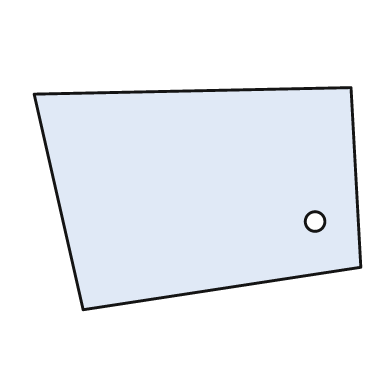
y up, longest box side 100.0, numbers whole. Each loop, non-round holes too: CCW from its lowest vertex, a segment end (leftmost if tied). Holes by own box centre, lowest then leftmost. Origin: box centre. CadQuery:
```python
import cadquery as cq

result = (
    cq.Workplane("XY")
    .moveTo(-35.0, -34.0)
    .lineTo(50.0, -21.0)
    .lineTo(47.0, 34.0)
    .lineTo(-50.0, 32.0)
    .close()
    .moveTo(36.0, -7.0)
    .circle(3.0)
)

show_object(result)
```